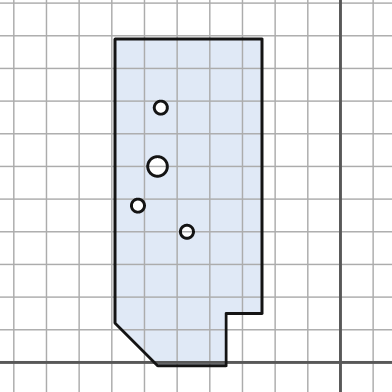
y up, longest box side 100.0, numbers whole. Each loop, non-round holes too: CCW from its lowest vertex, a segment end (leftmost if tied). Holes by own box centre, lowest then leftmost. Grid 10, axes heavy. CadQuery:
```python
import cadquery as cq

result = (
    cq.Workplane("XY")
    .moveTo(-56.0, -1.0)
    .lineTo(-35.0, -1.0)
    .lineTo(-35.0, 15.0)
    .lineTo(-24.0, 15.0)
    .lineTo(-24.0, 99.0)
    .lineTo(-69.0, 99.0)
    .lineTo(-69.0, 12.0)
    .close()
    .moveTo(-47.0, 40.0)
    .circle(2.0)
    .moveTo(-62.0, 48.0)
    .circle(2.0)
    .moveTo(-56.0, 60.0)
    .circle(3.0)
    .moveTo(-55.0, 78.0)
    .circle(2.0)
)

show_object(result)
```